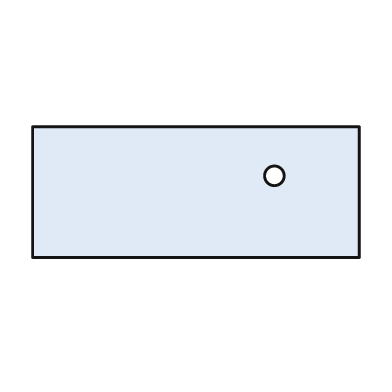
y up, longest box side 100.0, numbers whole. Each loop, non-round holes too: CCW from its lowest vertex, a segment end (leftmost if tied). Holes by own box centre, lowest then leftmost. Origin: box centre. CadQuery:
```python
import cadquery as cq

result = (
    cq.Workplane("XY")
    .moveTo(-50.0, -20.0)
    .lineTo(50.0, -20.0)
    .lineTo(50.0, 20.0)
    .lineTo(-50.0, 20.0)
    .close()
    .moveTo(24.0, 5.0)
    .circle(3.0)
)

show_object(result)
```